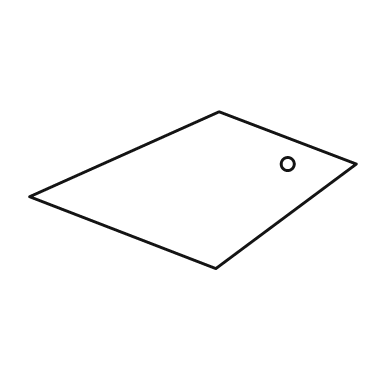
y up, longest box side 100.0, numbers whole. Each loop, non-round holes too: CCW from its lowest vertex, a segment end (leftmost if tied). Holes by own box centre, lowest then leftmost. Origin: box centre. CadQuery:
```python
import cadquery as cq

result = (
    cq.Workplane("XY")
    .moveTo(7.0, -24.0)
    .lineTo(50.0, 8.0)
    .lineTo(8.0, 24.0)
    .lineTo(-50.0, -2.0)
    .close()
    .moveTo(29.0, 8.0)
    .circle(2.0)
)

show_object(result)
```